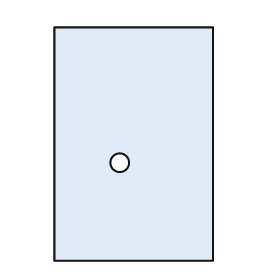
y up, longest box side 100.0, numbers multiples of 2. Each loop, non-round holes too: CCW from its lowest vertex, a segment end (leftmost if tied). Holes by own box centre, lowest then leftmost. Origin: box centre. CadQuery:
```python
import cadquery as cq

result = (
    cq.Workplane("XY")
    .moveTo(-34.0, -50.0)
    .lineTo(34.0, -50.0)
    .lineTo(34.0, 50.0)
    .lineTo(-34.0, 50.0)
    .close()
    .moveTo(-6.0, -8.0)
    .circle(4.0)
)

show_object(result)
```